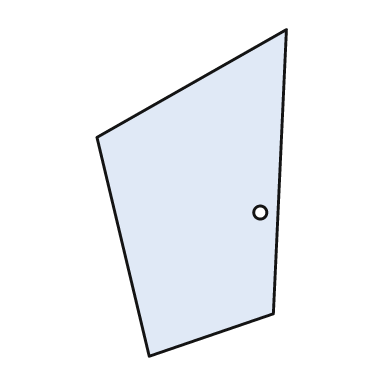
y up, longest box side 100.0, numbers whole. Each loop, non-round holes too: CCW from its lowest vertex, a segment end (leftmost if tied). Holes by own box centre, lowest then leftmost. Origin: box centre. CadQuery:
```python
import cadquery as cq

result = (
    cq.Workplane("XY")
    .moveTo(-13.0, -50.0)
    .lineTo(25.0, -37.0)
    .lineTo(29.0, 50.0)
    .lineTo(-29.0, 17.0)
    .close()
    .moveTo(21.0, -6.0)
    .circle(2.0)
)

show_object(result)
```